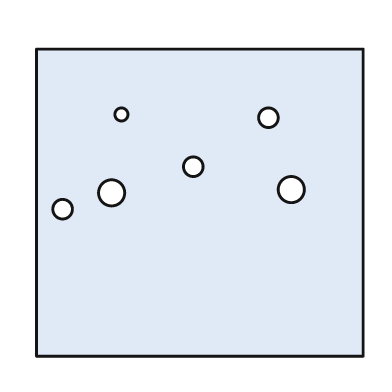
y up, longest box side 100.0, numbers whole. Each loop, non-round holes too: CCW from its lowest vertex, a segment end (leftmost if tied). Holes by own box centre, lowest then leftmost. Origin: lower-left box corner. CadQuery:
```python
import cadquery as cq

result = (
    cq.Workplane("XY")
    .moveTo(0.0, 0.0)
    .lineTo(100.0, 0.0)
    .lineTo(100.0, 94.0)
    .lineTo(0.0, 94.0)
    .close()
    .moveTo(8.0, 45.0)
    .circle(3.0)
    .moveTo(23.0, 50.0)
    .circle(4.0)
    .moveTo(78.0, 51.0)
    .circle(4.0)
    .moveTo(48.0, 58.0)
    .circle(3.0)
    .moveTo(71.0, 73.0)
    .circle(3.0)
    .moveTo(26.0, 74.0)
    .circle(2.0)
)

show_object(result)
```